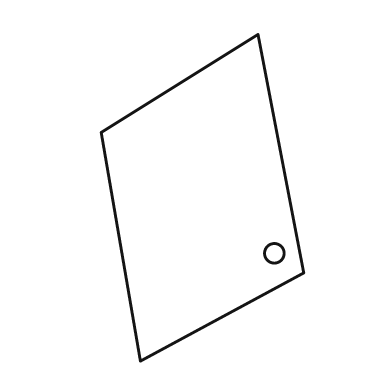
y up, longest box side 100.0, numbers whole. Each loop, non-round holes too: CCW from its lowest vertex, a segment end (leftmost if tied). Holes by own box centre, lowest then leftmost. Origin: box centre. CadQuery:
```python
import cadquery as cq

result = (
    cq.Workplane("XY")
    .moveTo(-19.0, -50.0)
    .lineTo(31.0, -23.0)
    .lineTo(17.0, 50.0)
    .lineTo(-31.0, 20.0)
    .close()
    .moveTo(22.0, -17.0)
    .circle(3.0)
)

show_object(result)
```